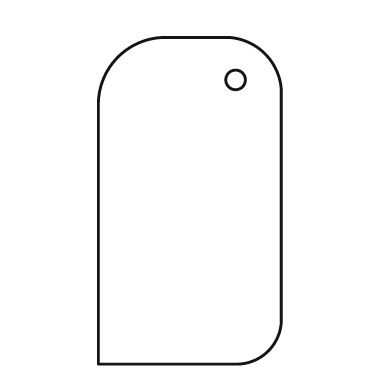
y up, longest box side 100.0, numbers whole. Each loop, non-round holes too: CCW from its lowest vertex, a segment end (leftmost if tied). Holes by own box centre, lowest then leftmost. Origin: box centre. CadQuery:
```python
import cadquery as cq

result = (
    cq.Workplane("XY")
    .moveTo(-28.0, -50.0)
    .lineTo(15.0, -50.0)
    .threePointArc((24.0, -46.0), (28.0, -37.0))
    .lineTo(28.0, 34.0)
    .threePointArc((23.0, 45.0), (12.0, 50.0))
    .lineTo(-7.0, 50.0)
    .threePointArc((-22.0, 44.0), (-28.0, 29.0))
    .close()
    .moveTo(14.0, 37.0)
    .circle(3.0)
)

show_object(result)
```